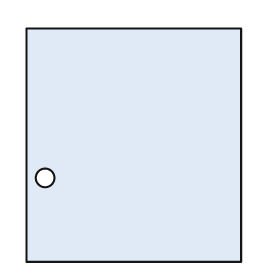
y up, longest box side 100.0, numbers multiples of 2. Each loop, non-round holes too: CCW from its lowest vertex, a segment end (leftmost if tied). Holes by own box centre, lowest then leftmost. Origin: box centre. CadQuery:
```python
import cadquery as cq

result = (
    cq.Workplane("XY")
    .moveTo(-46.0, -50.0)
    .lineTo(46.0, -50.0)
    .lineTo(46.0, 50.0)
    .lineTo(-46.0, 50.0)
    .close()
    .moveTo(-38.0, -14.0)
    .circle(4.0)
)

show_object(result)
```